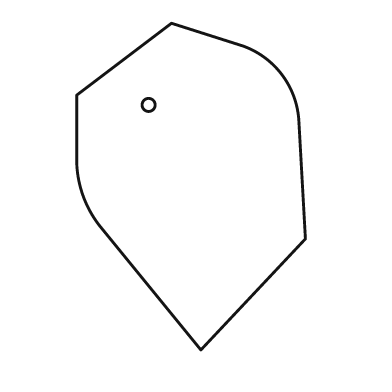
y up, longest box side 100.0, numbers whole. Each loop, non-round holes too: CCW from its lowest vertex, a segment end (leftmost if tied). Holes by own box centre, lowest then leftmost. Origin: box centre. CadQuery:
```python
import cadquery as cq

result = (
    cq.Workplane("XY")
    .moveTo(3.0, -50.0)
    .lineTo(35.0, -16.0)
    .lineTo(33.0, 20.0)
    .threePointArc((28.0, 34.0), (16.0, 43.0))
    .lineTo(-6.0, 50.0)
    .lineTo(-35.0, 28.0)
    .lineTo(-35.0, 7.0)
    .threePointArc((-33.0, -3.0), (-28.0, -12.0))
    .close()
    .moveTo(-13.0, 25.0)
    .circle(2.0)
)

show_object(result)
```